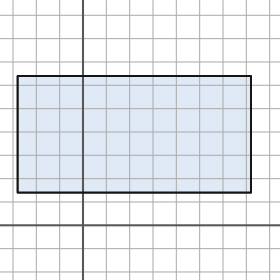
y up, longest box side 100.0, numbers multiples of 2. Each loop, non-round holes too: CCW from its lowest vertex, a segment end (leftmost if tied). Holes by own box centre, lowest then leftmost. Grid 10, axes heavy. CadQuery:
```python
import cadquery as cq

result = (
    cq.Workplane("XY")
    .moveTo(-28.0, 14.0)
    .lineTo(72.0, 14.0)
    .lineTo(72.0, 64.0)
    .lineTo(-28.0, 64.0)
    .close()
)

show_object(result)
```